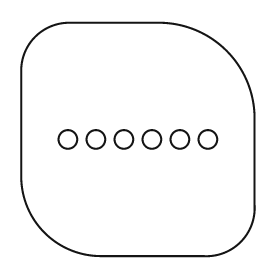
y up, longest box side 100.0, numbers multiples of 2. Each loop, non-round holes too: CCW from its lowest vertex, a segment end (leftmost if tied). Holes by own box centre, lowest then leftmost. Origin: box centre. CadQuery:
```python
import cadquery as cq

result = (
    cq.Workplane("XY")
    .moveTo(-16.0, -50.0)
    .lineTo(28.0, -50.0)
    .threePointArc((44.0, -44.0), (50.0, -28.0))
    .lineTo(50.0, 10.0)
    .threePointArc((38.0, 38.0), (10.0, 50.0))
    .lineTo(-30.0, 50.0)
    .threePointArc((-44.0, 44.0), (-50.0, 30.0))
    .lineTo(-50.0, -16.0)
    .threePointArc((-40.0, -40.0), (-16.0, -50.0))
    .close()
    .moveTo(-30.0, 0.0)
    .circle(4.0)
    .moveTo(-18.0, 0.0)
    .circle(4.0)
    .moveTo(-6.0, 0.0)
    .circle(4.0)
    .moveTo(6.0, 0.0)
    .circle(4.0)
    .moveTo(18.0, 0.0)
    .circle(4.0)
    .moveTo(30.0, 0.0)
    .circle(4.0)
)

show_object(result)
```